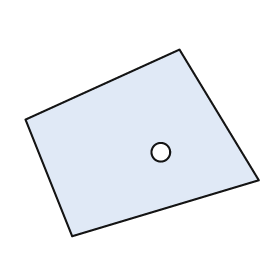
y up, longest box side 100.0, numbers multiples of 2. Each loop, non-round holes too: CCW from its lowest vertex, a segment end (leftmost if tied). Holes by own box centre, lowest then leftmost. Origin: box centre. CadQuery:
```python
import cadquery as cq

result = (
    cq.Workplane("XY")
    .moveTo(-30.0, -40.0)
    .lineTo(50.0, -16.0)
    .lineTo(16.0, 40.0)
    .lineTo(-50.0, 10.0)
    .close()
    .moveTo(8.0, -4.0)
    .circle(4.0)
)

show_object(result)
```